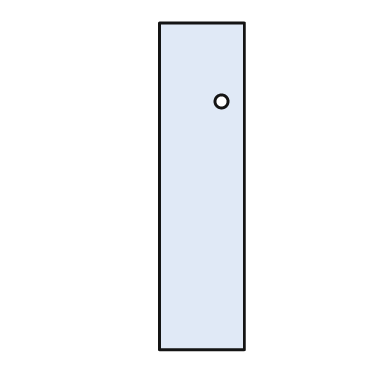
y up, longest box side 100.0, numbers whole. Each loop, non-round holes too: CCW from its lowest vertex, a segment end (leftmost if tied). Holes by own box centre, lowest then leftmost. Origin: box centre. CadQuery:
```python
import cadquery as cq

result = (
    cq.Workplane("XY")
    .moveTo(-13.0, -50.0)
    .lineTo(13.0, -50.0)
    .lineTo(13.0, 50.0)
    .lineTo(-13.0, 50.0)
    .close()
    .moveTo(6.0, 26.0)
    .circle(2.0)
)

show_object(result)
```